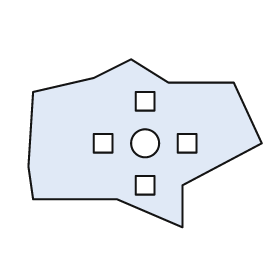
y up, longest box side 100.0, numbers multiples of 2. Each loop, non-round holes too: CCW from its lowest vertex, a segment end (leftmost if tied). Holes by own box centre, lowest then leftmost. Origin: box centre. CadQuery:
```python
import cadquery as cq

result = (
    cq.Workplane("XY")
    .moveTo(16.0, -36.0)
    .lineTo(16.0, -18.0)
    .lineTo(50.0, 0.0)
    .lineTo(38.0, 26.0)
    .lineTo(10.0, 26.0)
    .lineTo(-6.0, 36.0)
    .lineTo(-22.0, 28.0)
    .lineTo(-48.0, 22.0)
    .lineTo(-50.0, -10.0)
    .lineTo(-48.0, -24.0)
    .lineTo(-12.0, -24.0)
    .close()
    .moveTo(-4.0, -22.0)
    .lineTo(4.0, -22.0)
    .lineTo(4.0, -14.0)
    .lineTo(-4.0, -14.0)
    .close()
    .moveTo(-22.0, -4.0)
    .lineTo(-14.0, -4.0)
    .lineTo(-14.0, 4.0)
    .lineTo(-22.0, 4.0)
    .close()
    .moveTo(0.0, 0.0)
    .circle(6.0)
    .moveTo(14.0, -4.0)
    .lineTo(22.0, -4.0)
    .lineTo(22.0, 4.0)
    .lineTo(14.0, 4.0)
    .close()
    .moveTo(-4.0, 14.0)
    .lineTo(4.0, 14.0)
    .lineTo(4.0, 22.0)
    .lineTo(-4.0, 22.0)
    .close()
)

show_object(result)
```